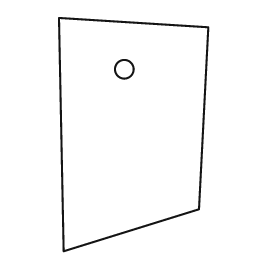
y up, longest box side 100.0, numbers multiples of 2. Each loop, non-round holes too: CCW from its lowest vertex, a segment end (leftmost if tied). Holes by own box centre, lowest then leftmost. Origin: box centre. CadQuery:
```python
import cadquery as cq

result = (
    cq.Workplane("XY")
    .moveTo(-30.0, -50.0)
    .lineTo(28.0, -32.0)
    .lineTo(32.0, 46.0)
    .lineTo(-32.0, 50.0)
    .close()
    .moveTo(-4.0, 28.0)
    .circle(4.0)
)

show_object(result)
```